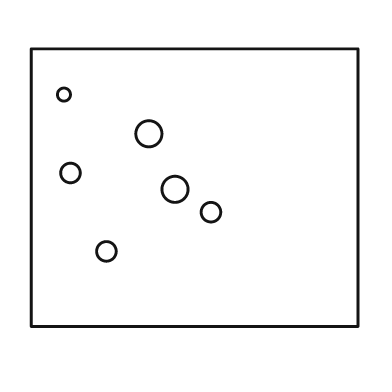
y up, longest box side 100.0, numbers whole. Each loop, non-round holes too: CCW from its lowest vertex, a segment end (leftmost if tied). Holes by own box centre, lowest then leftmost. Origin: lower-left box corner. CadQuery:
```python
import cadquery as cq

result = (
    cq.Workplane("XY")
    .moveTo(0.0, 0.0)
    .lineTo(100.0, 0.0)
    .lineTo(100.0, 85.0)
    .lineTo(0.0, 85.0)
    .close()
    .moveTo(23.0, 23.0)
    .circle(3.0)
    .moveTo(55.0, 35.0)
    .circle(3.0)
    .moveTo(44.0, 42.0)
    .circle(4.0)
    .moveTo(12.0, 47.0)
    .circle(3.0)
    .moveTo(36.0, 59.0)
    .circle(4.0)
    .moveTo(10.0, 71.0)
    .circle(2.0)
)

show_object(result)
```